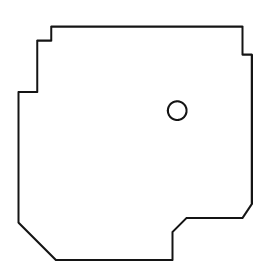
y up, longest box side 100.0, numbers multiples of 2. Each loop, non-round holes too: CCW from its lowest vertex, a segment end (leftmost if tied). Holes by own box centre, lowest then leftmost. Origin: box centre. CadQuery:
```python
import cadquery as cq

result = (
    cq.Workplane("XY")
    .moveTo(-34.0, -50.0)
    .lineTo(16.0, -50.0)
    .lineTo(16.0, -38.0)
    .lineTo(22.0, -32.0)
    .lineTo(46.0, -32.0)
    .lineTo(50.0, -26.0)
    .lineTo(50.0, 38.0)
    .lineTo(46.0, 38.0)
    .lineTo(46.0, 50.0)
    .lineTo(-36.0, 50.0)
    .lineTo(-36.0, 44.0)
    .lineTo(-42.0, 44.0)
    .lineTo(-42.0, 22.0)
    .lineTo(-50.0, 22.0)
    .lineTo(-50.0, -34.0)
    .close()
    .moveTo(18.0, 14.0)
    .circle(4.0)
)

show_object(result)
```